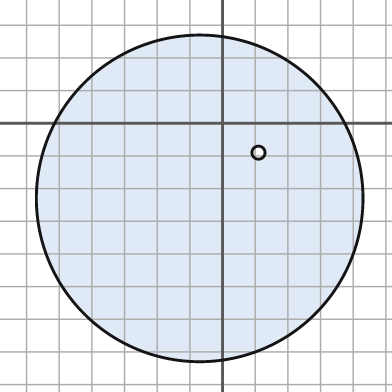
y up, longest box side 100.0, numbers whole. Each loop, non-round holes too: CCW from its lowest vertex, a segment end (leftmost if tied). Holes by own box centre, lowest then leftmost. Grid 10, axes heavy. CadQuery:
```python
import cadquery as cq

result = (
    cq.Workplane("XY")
    .moveTo(-7.0, -23.0)
    .circle(50.0)
    .moveTo(11.0, -9.0)
    .circle(2.0)
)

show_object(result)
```